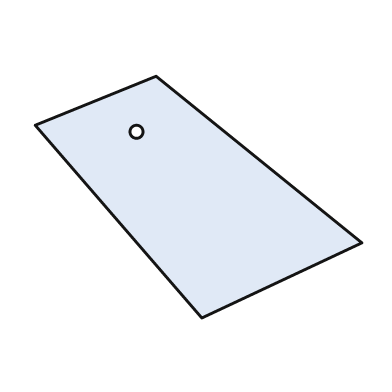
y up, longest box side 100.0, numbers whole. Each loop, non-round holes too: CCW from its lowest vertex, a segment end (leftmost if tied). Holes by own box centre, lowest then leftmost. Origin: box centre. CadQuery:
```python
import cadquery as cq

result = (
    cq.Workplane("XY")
    .moveTo(1.0, -37.0)
    .lineTo(50.0, -14.0)
    .lineTo(-13.0, 37.0)
    .lineTo(-50.0, 22.0)
    .close()
    .moveTo(-19.0, 20.0)
    .circle(2.0)
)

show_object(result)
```